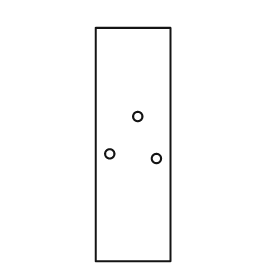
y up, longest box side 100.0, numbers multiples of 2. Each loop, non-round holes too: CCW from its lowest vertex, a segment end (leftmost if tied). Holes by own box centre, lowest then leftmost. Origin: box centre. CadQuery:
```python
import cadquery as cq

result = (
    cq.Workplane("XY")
    .moveTo(-16.0, -50.0)
    .lineTo(16.0, -50.0)
    .lineTo(16.0, 50.0)
    .lineTo(-16.0, 50.0)
    .close()
    .moveTo(10.0, -6.0)
    .circle(2.0)
    .moveTo(-10.0, -4.0)
    .circle(2.0)
    .moveTo(2.0, 12.0)
    .circle(2.0)
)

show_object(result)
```